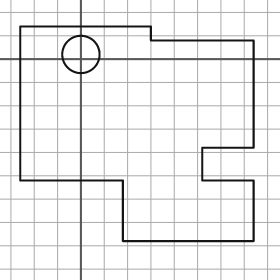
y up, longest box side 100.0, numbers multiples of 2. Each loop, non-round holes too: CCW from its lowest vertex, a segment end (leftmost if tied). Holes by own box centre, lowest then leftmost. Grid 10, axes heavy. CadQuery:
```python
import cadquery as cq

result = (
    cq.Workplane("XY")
    .moveTo(18.0, -78.0)
    .lineTo(74.0, -78.0)
    .lineTo(74.0, -52.0)
    .lineTo(52.0, -52.0)
    .lineTo(52.0, -38.0)
    .lineTo(74.0, -38.0)
    .lineTo(74.0, 8.0)
    .lineTo(30.0, 8.0)
    .lineTo(30.0, 14.0)
    .lineTo(-26.0, 14.0)
    .lineTo(-26.0, -52.0)
    .lineTo(18.0, -52.0)
    .close()
    .moveTo(0.0, 2.0)
    .circle(8.0)
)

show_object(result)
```